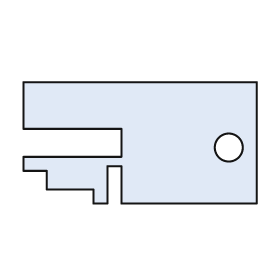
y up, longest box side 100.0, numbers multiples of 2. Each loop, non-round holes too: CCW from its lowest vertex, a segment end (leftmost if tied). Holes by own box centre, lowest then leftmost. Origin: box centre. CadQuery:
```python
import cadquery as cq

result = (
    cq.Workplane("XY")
    .moveTo(-20.0, -26.0)
    .lineTo(-14.0, -26.0)
    .lineTo(-14.0, -10.0)
    .lineTo(-8.0, -10.0)
    .lineTo(-8.0, -26.0)
    .lineTo(50.0, -26.0)
    .lineTo(50.0, 26.0)
    .lineTo(-50.0, 26.0)
    .lineTo(-50.0, 6.0)
    .lineTo(-8.0, 6.0)
    .lineTo(-8.0, -6.0)
    .lineTo(-50.0, -6.0)
    .lineTo(-50.0, -12.0)
    .lineTo(-40.0, -12.0)
    .lineTo(-40.0, -20.0)
    .lineTo(-20.0, -20.0)
    .close()
    .moveTo(38.0, -2.0)
    .circle(6.0)
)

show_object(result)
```